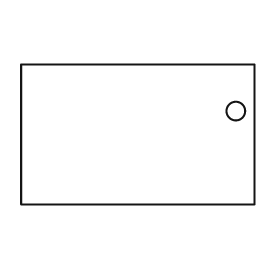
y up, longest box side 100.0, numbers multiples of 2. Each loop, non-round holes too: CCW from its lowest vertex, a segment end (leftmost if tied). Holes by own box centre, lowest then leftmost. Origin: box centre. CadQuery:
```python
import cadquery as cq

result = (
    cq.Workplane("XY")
    .moveTo(-50.0, -30.0)
    .lineTo(50.0, -30.0)
    .lineTo(50.0, 30.0)
    .lineTo(-50.0, 30.0)
    .close()
    .moveTo(42.0, 10.0)
    .circle(4.0)
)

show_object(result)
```